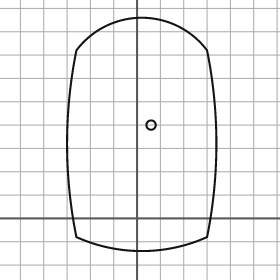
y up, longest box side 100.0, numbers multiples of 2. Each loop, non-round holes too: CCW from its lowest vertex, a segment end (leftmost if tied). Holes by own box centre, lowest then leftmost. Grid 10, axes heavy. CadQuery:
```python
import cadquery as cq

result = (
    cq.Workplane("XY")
    .moveTo(-26.0, -8.0)
    .threePointArc((2.0, -14.0), (30.0, -8.0))
    .threePointArc((34.0, 32.0), (30.0, 72.0))
    .threePointArc((2.0, 86.0), (-26.0, 72.0))
    .threePointArc((-30.0, 32.0), (-26.0, -8.0))
    .close()
    .moveTo(6.0, 40.0)
    .circle(2.0)
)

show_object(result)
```